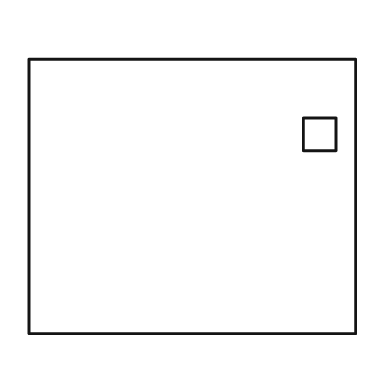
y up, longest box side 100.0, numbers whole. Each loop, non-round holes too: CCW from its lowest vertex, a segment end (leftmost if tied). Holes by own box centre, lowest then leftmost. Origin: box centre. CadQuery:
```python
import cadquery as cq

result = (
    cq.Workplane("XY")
    .moveTo(-50.0, -42.0)
    .lineTo(50.0, -42.0)
    .lineTo(50.0, 42.0)
    .lineTo(-50.0, 42.0)
    .close()
    .moveTo(34.0, 14.0)
    .lineTo(44.0, 14.0)
    .lineTo(44.0, 24.0)
    .lineTo(34.0, 24.0)
    .close()
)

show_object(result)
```